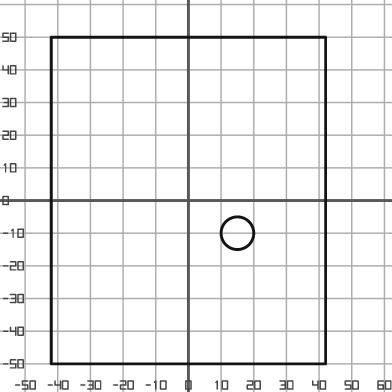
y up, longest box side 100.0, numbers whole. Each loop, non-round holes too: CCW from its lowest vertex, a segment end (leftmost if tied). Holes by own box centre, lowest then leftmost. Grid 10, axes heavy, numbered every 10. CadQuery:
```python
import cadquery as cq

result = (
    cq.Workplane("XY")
    .moveTo(-42.0, -50.0)
    .lineTo(42.0, -50.0)
    .lineTo(42.0, 50.0)
    .lineTo(-42.0, 50.0)
    .close()
    .moveTo(15.0, -10.0)
    .circle(5.0)
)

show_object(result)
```